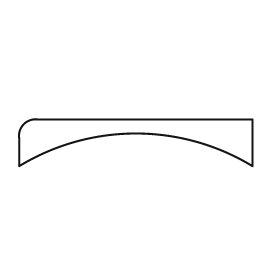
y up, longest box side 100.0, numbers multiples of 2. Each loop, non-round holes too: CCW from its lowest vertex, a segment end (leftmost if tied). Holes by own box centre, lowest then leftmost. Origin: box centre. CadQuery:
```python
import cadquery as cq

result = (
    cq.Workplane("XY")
    .moveTo(-50.0, -10.0)
    .threePointArc((0.0, 4.0), (50.0, -10.0))
    .lineTo(50.0, 10.0)
    .lineTo(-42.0, 10.0)
    .threePointArc((-48.0, 8.0), (-50.0, 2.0))
    .close()
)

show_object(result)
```